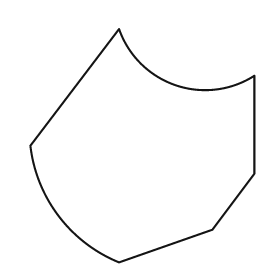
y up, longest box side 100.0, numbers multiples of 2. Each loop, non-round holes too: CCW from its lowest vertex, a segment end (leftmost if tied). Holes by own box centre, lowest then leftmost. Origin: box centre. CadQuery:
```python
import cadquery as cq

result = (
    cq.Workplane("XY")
    .moveTo(-10.0, -50.0)
    .lineTo(30.0, -36.0)
    .lineTo(48.0, -12.0)
    .lineTo(48.0, 30.0)
    .threePointArc((14.0, 26.0), (-10.0, 50.0))
    .lineTo(-48.0, 0.0)
    .threePointArc((-36.0, -30.0), (-10.0, -50.0))
    .close()
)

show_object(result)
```